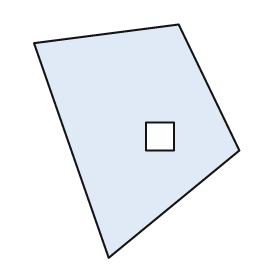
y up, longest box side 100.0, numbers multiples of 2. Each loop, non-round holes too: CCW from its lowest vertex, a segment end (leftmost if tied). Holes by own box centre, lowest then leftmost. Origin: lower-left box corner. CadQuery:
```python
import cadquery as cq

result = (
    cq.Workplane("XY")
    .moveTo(32.0, 0.0)
    .lineTo(88.0, 46.0)
    .lineTo(62.0, 100.0)
    .lineTo(0.0, 92.0)
    .close()
    .moveTo(48.0, 46.0)
    .lineTo(60.0, 46.0)
    .lineTo(60.0, 58.0)
    .lineTo(48.0, 58.0)
    .close()
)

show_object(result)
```